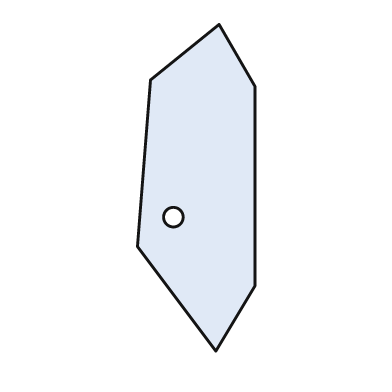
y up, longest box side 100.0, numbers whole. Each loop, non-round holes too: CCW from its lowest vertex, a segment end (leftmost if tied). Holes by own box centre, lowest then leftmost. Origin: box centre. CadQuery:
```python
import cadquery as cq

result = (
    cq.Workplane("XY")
    .moveTo(6.0, -50.0)
    .lineTo(18.0, -30.0)
    .lineTo(18.0, 31.0)
    .lineTo(7.0, 50.0)
    .lineTo(-14.0, 33.0)
    .lineTo(-18.0, -18.0)
    .close()
    .moveTo(-7.0, -9.0)
    .circle(3.0)
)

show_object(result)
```